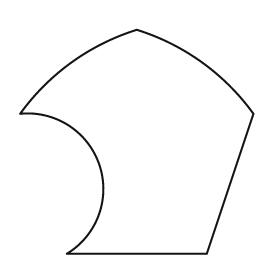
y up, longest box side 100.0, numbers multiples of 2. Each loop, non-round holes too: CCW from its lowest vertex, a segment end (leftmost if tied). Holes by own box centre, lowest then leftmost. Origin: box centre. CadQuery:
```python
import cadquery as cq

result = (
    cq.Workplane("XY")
    .moveTo(-30.0, -48.0)
    .lineTo(30.0, -48.0)
    .lineTo(50.0, 12.0)
    .threePointArc((28.0, 34.0), (0.0, 48.0))
    .threePointArc((-28.0, 34.0), (-50.0, 12.0))
    .threePointArc((-16.0, -10.0), (-30.0, -48.0))
    .close()
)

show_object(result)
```